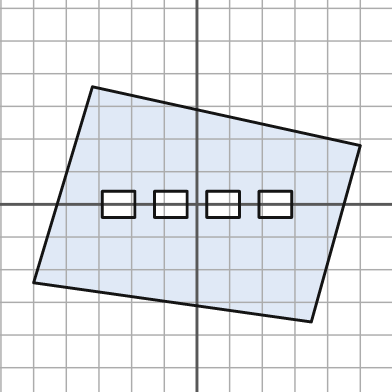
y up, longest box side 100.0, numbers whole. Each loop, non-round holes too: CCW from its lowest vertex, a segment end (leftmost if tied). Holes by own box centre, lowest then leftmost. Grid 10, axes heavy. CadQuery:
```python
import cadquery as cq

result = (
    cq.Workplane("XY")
    .moveTo(35.0, -36.0)
    .lineTo(50.0, 18.0)
    .lineTo(-32.0, 36.0)
    .lineTo(-50.0, -24.0)
    .close()
    .moveTo(-29.0, -4.0)
    .lineTo(-19.0, -4.0)
    .lineTo(-19.0, 4.0)
    .lineTo(-29.0, 4.0)
    .close()
    .moveTo(-13.0, -4.0)
    .lineTo(-3.0, -4.0)
    .lineTo(-3.0, 4.0)
    .lineTo(-13.0, 4.0)
    .close()
    .moveTo(3.0, -4.0)
    .lineTo(13.0, -4.0)
    .lineTo(13.0, 4.0)
    .lineTo(3.0, 4.0)
    .close()
    .moveTo(19.0, -4.0)
    .lineTo(29.0, -4.0)
    .lineTo(29.0, 4.0)
    .lineTo(19.0, 4.0)
    .close()
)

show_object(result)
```